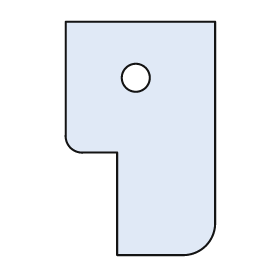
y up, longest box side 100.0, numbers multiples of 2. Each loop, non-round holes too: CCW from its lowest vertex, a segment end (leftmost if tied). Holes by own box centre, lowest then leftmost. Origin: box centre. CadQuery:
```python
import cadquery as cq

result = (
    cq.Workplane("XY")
    .moveTo(-10.0, -50.0)
    .lineTo(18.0, -50.0)
    .threePointArc((28.0, -46.0), (32.0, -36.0))
    .lineTo(32.0, 50.0)
    .lineTo(-32.0, 50.0)
    .lineTo(-32.0, 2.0)
    .threePointArc((-30.0, -4.0), (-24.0, -6.0))
    .lineTo(-10.0, -6.0)
    .close()
    .moveTo(-2.0, 26.0)
    .circle(6.0)
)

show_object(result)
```